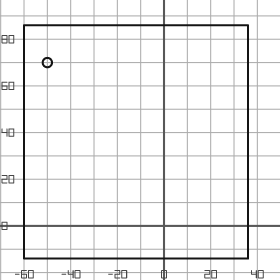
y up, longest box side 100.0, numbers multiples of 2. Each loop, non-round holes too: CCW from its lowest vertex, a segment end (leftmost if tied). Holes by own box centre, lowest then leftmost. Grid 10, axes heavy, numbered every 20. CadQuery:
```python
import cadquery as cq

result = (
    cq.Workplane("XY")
    .moveTo(-60.0, -14.0)
    .lineTo(36.0, -14.0)
    .lineTo(36.0, 86.0)
    .lineTo(-60.0, 86.0)
    .close()
    .moveTo(-50.0, 70.0)
    .circle(2.0)
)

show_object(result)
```